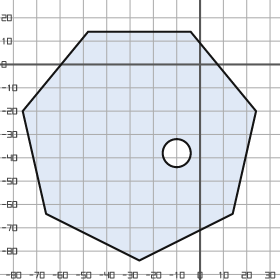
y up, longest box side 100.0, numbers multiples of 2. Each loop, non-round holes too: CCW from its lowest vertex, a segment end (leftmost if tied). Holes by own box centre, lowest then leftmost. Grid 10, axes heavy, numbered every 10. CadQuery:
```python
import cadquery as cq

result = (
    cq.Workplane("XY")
    .moveTo(-26.0, -84.0)
    .lineTo(14.0, -64.0)
    .lineTo(24.0, -20.0)
    .lineTo(-4.0, 14.0)
    .lineTo(-48.0, 14.0)
    .lineTo(-76.0, -20.0)
    .lineTo(-66.0, -64.0)
    .close()
    .moveTo(-10.0, -38.0)
    .circle(6.0)
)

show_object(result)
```